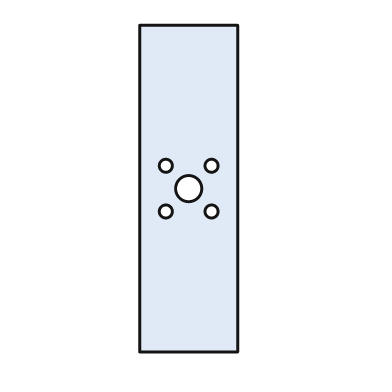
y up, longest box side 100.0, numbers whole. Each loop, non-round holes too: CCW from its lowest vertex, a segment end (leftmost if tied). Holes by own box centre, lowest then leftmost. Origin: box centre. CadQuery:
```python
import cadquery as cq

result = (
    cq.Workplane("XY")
    .moveTo(-15.0, -50.0)
    .lineTo(15.0, -50.0)
    .lineTo(15.0, 50.0)
    .lineTo(-15.0, 50.0)
    .close()
    .moveTo(-7.0, -7.0)
    .circle(2.0)
    .moveTo(7.0, -7.0)
    .circle(2.0)
    .moveTo(0.0, 0.0)
    .circle(4.0)
    .moveTo(-7.0, 7.0)
    .circle(2.0)
    .moveTo(7.0, 7.0)
    .circle(2.0)
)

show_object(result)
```